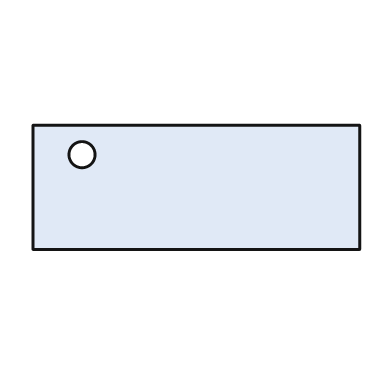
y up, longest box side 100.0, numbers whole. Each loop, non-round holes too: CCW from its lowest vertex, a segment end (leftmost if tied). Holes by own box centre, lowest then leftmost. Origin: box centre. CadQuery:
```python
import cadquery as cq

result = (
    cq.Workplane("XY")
    .moveTo(-50.0, -19.0)
    .lineTo(50.0, -19.0)
    .lineTo(50.0, 19.0)
    .lineTo(-50.0, 19.0)
    .close()
    .moveTo(-35.0, 10.0)
    .circle(4.0)
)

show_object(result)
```